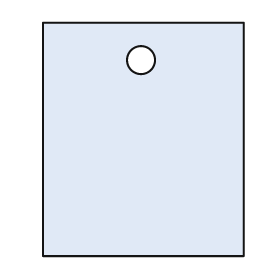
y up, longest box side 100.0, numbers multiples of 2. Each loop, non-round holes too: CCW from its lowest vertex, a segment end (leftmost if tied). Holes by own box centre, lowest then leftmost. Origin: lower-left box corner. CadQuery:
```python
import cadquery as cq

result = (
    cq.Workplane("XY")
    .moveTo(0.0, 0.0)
    .lineTo(86.0, 0.0)
    .lineTo(86.0, 100.0)
    .lineTo(0.0, 100.0)
    .close()
    .moveTo(42.0, 84.0)
    .circle(6.0)
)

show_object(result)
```